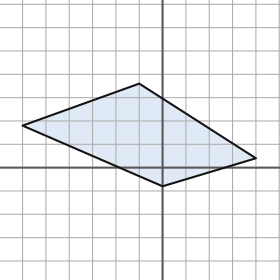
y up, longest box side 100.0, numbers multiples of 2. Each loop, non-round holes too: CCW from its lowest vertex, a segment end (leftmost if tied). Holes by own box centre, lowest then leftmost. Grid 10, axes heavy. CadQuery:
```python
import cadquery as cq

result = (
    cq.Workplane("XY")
    .moveTo(0.0, -8.0)
    .lineTo(40.0, 4.0)
    .lineTo(-10.0, 36.0)
    .lineTo(-60.0, 18.0)
    .close()
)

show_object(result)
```